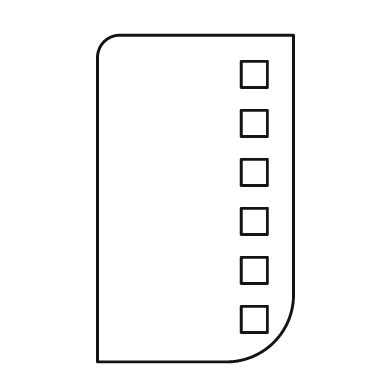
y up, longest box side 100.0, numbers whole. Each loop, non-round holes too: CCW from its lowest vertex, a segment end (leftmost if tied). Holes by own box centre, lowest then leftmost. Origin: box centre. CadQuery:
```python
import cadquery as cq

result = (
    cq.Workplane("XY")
    .moveTo(-30.0, -50.0)
    .lineTo(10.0, -50.0)
    .threePointArc((24.0, -44.0), (30.0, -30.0))
    .lineTo(30.0, 50.0)
    .lineTo(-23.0, 50.0)
    .threePointArc((-28.0, 48.0), (-30.0, 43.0))
    .close()
    .moveTo(14.0, -41.0)
    .lineTo(22.0, -41.0)
    .lineTo(22.0, -33.0)
    .lineTo(14.0, -33.0)
    .close()
    .moveTo(14.0, -26.0)
    .lineTo(22.0, -26.0)
    .lineTo(22.0, -18.0)
    .lineTo(14.0, -18.0)
    .close()
    .moveTo(14.0, -11.0)
    .lineTo(22.0, -11.0)
    .lineTo(22.0, -3.0)
    .lineTo(14.0, -3.0)
    .close()
    .moveTo(14.0, 4.0)
    .lineTo(22.0, 4.0)
    .lineTo(22.0, 12.0)
    .lineTo(14.0, 12.0)
    .close()
    .moveTo(14.0, 19.0)
    .lineTo(22.0, 19.0)
    .lineTo(22.0, 27.0)
    .lineTo(14.0, 27.0)
    .close()
    .moveTo(14.0, 34.0)
    .lineTo(22.0, 34.0)
    .lineTo(22.0, 42.0)
    .lineTo(14.0, 42.0)
    .close()
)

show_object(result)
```